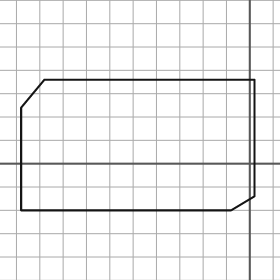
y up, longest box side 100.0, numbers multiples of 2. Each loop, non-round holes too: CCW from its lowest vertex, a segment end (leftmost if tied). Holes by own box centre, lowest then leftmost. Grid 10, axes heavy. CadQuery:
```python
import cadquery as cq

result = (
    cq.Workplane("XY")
    .moveTo(-98.0, -20.0)
    .lineTo(-8.0, -20.0)
    .lineTo(2.0, -14.0)
    .lineTo(2.0, 36.0)
    .lineTo(-88.0, 36.0)
    .lineTo(-98.0, 24.0)
    .close()
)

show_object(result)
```